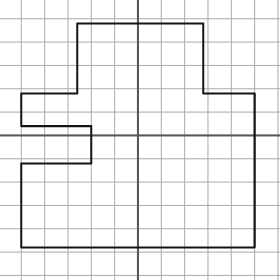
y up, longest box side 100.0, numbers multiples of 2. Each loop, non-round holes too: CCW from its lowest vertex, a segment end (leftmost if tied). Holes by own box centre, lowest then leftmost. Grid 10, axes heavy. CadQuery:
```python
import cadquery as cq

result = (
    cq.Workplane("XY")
    .moveTo(-50.0, -48.0)
    .lineTo(50.0, -48.0)
    .lineTo(50.0, 18.0)
    .lineTo(28.0, 18.0)
    .lineTo(28.0, 48.0)
    .lineTo(-26.0, 48.0)
    .lineTo(-26.0, 18.0)
    .lineTo(-50.0, 18.0)
    .lineTo(-50.0, 4.0)
    .lineTo(-20.0, 4.0)
    .lineTo(-20.0, -12.0)
    .lineTo(-50.0, -12.0)
    .close()
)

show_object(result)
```